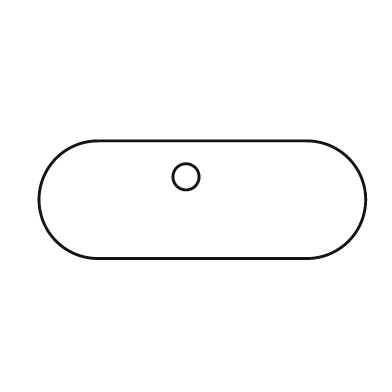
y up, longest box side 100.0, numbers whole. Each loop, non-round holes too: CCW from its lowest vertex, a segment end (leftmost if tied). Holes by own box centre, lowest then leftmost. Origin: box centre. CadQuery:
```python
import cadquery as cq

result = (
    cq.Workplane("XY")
    .moveTo(-32.0, -18.0)
    .lineTo(32.0, -18.0)
    .threePointArc((50.0, 0.0), (32.0, 18.0))
    .lineTo(-32.0, 18.0)
    .threePointArc((-50.0, 0.0), (-32.0, -18.0))
    .close()
    .moveTo(-5.0, 7.0)
    .circle(4.0)
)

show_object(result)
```